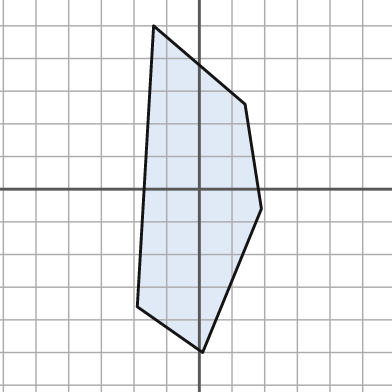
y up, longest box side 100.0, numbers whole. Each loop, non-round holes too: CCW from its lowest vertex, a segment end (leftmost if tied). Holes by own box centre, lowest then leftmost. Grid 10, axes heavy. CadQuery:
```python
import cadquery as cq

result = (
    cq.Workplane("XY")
    .moveTo(1.0, -50.0)
    .lineTo(19.0, -6.0)
    .lineTo(14.0, 26.0)
    .lineTo(-14.0, 50.0)
    .lineTo(-19.0, -36.0)
    .close()
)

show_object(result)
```